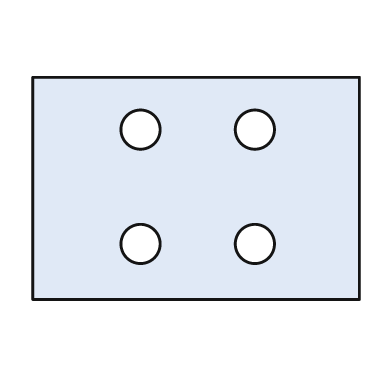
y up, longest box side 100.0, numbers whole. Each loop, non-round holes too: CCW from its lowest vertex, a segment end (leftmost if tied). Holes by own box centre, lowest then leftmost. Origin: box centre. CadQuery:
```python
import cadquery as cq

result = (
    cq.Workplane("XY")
    .moveTo(-50.0, -34.0)
    .lineTo(50.0, -34.0)
    .lineTo(50.0, 34.0)
    .lineTo(-50.0, 34.0)
    .close()
    .moveTo(-17.0, -17.0)
    .circle(6.0)
    .moveTo(18.0, -17.0)
    .circle(6.0)
    .moveTo(-17.0, 18.0)
    .circle(6.0)
    .moveTo(18.0, 18.0)
    .circle(6.0)
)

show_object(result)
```